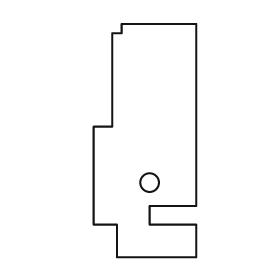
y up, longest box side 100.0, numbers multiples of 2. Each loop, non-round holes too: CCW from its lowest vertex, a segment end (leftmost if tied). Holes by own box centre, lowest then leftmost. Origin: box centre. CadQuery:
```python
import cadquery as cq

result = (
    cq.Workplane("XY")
    .moveTo(-12.0, -50.0)
    .lineTo(22.0, -50.0)
    .lineTo(22.0, -36.0)
    .lineTo(2.0, -36.0)
    .lineTo(2.0, -28.0)
    .lineTo(22.0, -28.0)
    .lineTo(22.0, 50.0)
    .lineTo(-10.0, 50.0)
    .lineTo(-10.0, 46.0)
    .lineTo(-14.0, 46.0)
    .lineTo(-14.0, 6.0)
    .lineTo(-22.0, 6.0)
    .lineTo(-22.0, -36.0)
    .lineTo(-12.0, -36.0)
    .close()
    .moveTo(2.0, -18.0)
    .circle(4.0)
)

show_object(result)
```